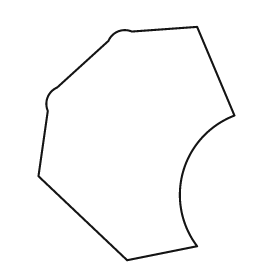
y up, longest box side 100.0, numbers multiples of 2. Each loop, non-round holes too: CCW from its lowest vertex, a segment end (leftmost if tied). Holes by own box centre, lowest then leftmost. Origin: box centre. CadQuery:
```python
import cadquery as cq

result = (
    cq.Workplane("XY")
    .moveTo(-4.0, -50.0)
    .lineTo(26.0, -44.0)
    .threePointArc((20.0, -12.0), (42.0, 12.0))
    .lineTo(26.0, 50.0)
    .lineTo(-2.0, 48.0)
    .threePointArc((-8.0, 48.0), (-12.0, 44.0))
    .lineTo(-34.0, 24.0)
    .threePointArc((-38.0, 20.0), (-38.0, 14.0))
    .lineTo(-42.0, -14.0)
    .close()
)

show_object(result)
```